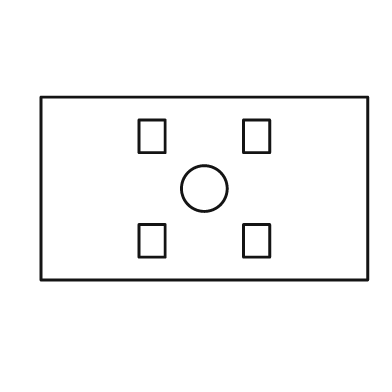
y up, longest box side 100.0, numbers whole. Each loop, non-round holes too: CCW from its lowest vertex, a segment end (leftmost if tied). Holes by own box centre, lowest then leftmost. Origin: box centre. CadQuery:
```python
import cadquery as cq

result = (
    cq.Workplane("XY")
    .moveTo(-50.0, -28.0)
    .lineTo(50.0, -28.0)
    .lineTo(50.0, 28.0)
    .lineTo(-50.0, 28.0)
    .close()
    .moveTo(-20.0, -21.0)
    .lineTo(-12.0, -21.0)
    .lineTo(-12.0, -11.0)
    .lineTo(-20.0, -11.0)
    .close()
    .moveTo(12.0, -21.0)
    .lineTo(20.0, -21.0)
    .lineTo(20.0, -11.0)
    .lineTo(12.0, -11.0)
    .close()
    .moveTo(0.0, 0.0)
    .circle(7.0)
    .moveTo(-20.0, 11.0)
    .lineTo(-12.0, 11.0)
    .lineTo(-12.0, 21.0)
    .lineTo(-20.0, 21.0)
    .close()
    .moveTo(12.0, 11.0)
    .lineTo(20.0, 11.0)
    .lineTo(20.0, 21.0)
    .lineTo(12.0, 21.0)
    .close()
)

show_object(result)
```